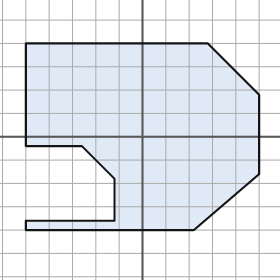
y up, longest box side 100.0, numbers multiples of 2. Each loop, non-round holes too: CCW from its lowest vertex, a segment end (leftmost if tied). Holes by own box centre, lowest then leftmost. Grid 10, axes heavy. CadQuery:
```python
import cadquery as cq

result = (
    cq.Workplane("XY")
    .moveTo(-50.0, -40.0)
    .lineTo(22.0, -40.0)
    .lineTo(50.0, -16.0)
    .lineTo(50.0, 18.0)
    .lineTo(28.0, 40.0)
    .lineTo(-50.0, 40.0)
    .lineTo(-50.0, -4.0)
    .lineTo(-26.0, -4.0)
    .lineTo(-12.0, -18.0)
    .lineTo(-12.0, -36.0)
    .lineTo(-50.0, -36.0)
    .close()
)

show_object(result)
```